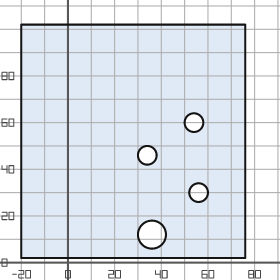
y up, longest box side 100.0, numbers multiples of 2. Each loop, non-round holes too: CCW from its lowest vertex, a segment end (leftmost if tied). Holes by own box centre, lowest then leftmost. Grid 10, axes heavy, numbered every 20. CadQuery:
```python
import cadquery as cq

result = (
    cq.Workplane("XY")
    .moveTo(-20.0, 2.0)
    .lineTo(76.0, 2.0)
    .lineTo(76.0, 102.0)
    .lineTo(-20.0, 102.0)
    .close()
    .moveTo(36.0, 12.0)
    .circle(6.0)
    .moveTo(56.0, 30.0)
    .circle(4.0)
    .moveTo(34.0, 46.0)
    .circle(4.0)
    .moveTo(54.0, 60.0)
    .circle(4.0)
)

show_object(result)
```